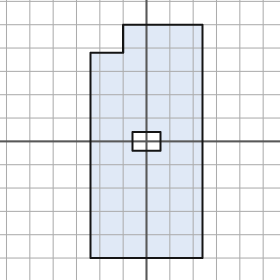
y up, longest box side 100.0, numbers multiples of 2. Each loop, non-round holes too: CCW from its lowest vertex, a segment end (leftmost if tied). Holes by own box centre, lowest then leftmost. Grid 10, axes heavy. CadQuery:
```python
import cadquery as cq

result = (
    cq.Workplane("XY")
    .moveTo(-24.0, -50.0)
    .lineTo(24.0, -50.0)
    .lineTo(24.0, 50.0)
    .lineTo(-10.0, 50.0)
    .lineTo(-10.0, 38.0)
    .lineTo(-24.0, 38.0)
    .close()
    .moveTo(-6.0, -4.0)
    .lineTo(6.0, -4.0)
    .lineTo(6.0, 4.0)
    .lineTo(-6.0, 4.0)
    .close()
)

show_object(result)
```